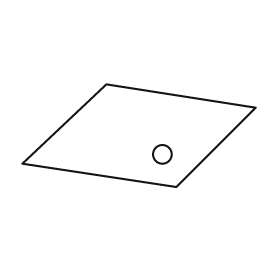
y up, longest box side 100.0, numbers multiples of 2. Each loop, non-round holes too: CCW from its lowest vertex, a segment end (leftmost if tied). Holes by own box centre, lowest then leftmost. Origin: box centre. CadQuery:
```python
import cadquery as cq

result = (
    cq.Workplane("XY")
    .moveTo(16.0, -22.0)
    .lineTo(50.0, 12.0)
    .lineTo(-14.0, 22.0)
    .lineTo(-50.0, -12.0)
    .close()
    .moveTo(10.0, -8.0)
    .circle(4.0)
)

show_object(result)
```